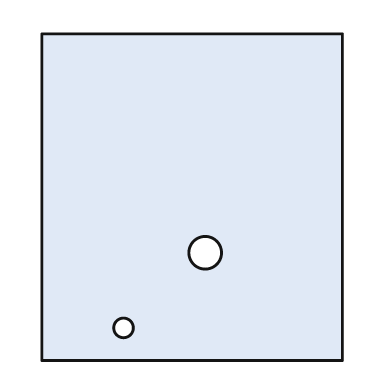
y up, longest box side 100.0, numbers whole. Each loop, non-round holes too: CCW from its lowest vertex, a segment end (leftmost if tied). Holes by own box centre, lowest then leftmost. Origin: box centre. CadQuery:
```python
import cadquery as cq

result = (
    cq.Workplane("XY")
    .moveTo(-46.0, -50.0)
    .lineTo(46.0, -50.0)
    .lineTo(46.0, 50.0)
    .lineTo(-46.0, 50.0)
    .close()
    .moveTo(-21.0, -40.0)
    .circle(3.0)
    .moveTo(4.0, -17.0)
    .circle(5.0)
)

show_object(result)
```